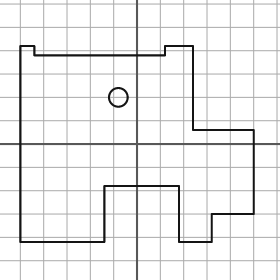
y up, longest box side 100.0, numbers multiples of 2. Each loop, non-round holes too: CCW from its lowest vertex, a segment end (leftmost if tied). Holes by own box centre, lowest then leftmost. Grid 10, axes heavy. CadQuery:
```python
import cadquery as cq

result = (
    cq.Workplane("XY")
    .moveTo(-50.0, -42.0)
    .lineTo(-14.0, -42.0)
    .lineTo(-14.0, -18.0)
    .lineTo(18.0, -18.0)
    .lineTo(18.0, -42.0)
    .lineTo(32.0, -42.0)
    .lineTo(32.0, -30.0)
    .lineTo(50.0, -30.0)
    .lineTo(50.0, 6.0)
    .lineTo(24.0, 6.0)
    .lineTo(24.0, 42.0)
    .lineTo(12.0, 42.0)
    .lineTo(12.0, 38.0)
    .lineTo(-44.0, 38.0)
    .lineTo(-44.0, 42.0)
    .lineTo(-50.0, 42.0)
    .close()
    .moveTo(-8.0, 20.0)
    .circle(4.0)
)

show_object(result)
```